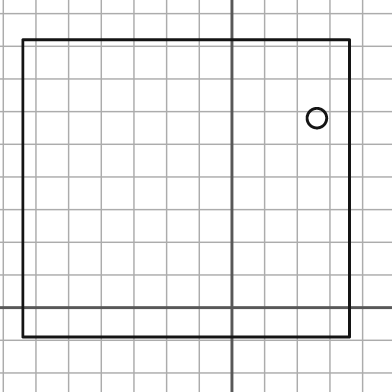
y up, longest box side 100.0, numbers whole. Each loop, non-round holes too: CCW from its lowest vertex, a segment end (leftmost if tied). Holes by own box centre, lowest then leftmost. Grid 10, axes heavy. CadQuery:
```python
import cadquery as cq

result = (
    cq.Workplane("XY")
    .moveTo(-64.0, -9.0)
    .lineTo(36.0, -9.0)
    .lineTo(36.0, 82.0)
    .lineTo(-64.0, 82.0)
    .close()
    .moveTo(26.0, 58.0)
    .circle(3.0)
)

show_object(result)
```